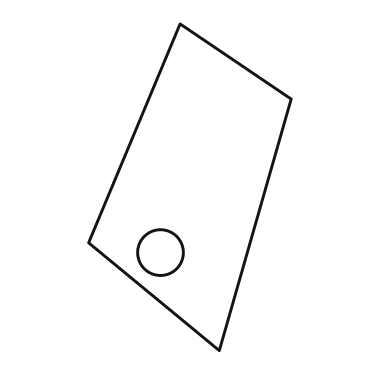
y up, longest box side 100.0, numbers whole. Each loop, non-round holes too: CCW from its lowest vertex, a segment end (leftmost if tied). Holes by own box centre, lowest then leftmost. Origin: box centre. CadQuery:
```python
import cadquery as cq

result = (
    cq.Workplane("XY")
    .moveTo(9.0, -50.0)
    .lineTo(31.0, 27.0)
    .lineTo(-3.0, 50.0)
    .lineTo(-31.0, -17.0)
    .close()
    .moveTo(-9.0, -20.0)
    .circle(7.0)
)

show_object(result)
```